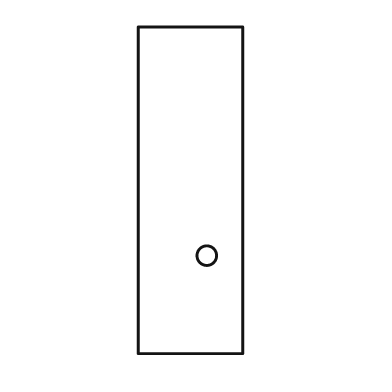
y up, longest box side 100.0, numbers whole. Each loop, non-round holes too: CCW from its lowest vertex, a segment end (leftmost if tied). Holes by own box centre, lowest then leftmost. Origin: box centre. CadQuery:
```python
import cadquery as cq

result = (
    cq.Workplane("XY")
    .moveTo(-16.0, -50.0)
    .lineTo(16.0, -50.0)
    .lineTo(16.0, 50.0)
    .lineTo(-16.0, 50.0)
    .close()
    .moveTo(5.0, -20.0)
    .circle(3.0)
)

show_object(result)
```